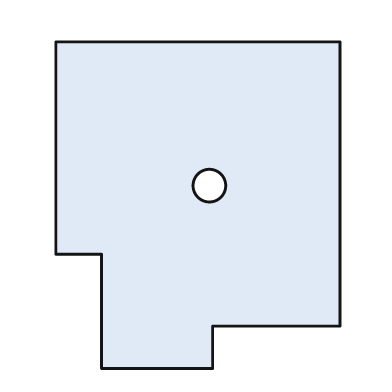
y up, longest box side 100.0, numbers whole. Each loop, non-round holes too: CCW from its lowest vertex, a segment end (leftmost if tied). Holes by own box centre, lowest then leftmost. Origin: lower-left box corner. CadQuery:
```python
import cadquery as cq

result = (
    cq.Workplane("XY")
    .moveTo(14.0, 0.0)
    .lineTo(48.0, 0.0)
    .lineTo(48.0, 13.0)
    .lineTo(87.0, 13.0)
    .lineTo(87.0, 100.0)
    .lineTo(0.0, 100.0)
    .lineTo(0.0, 35.0)
    .lineTo(14.0, 35.0)
    .close()
    .moveTo(47.0, 56.0)
    .circle(5.0)
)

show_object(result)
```